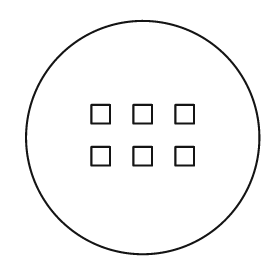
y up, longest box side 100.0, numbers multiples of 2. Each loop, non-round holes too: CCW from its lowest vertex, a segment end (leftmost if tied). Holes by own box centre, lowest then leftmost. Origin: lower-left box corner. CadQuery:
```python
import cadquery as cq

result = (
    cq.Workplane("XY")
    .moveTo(50.0, 50.0)
    .circle(50.0)
    .moveTo(28.0, 38.0)
    .lineTo(36.0, 38.0)
    .lineTo(36.0, 46.0)
    .lineTo(28.0, 46.0)
    .close()
    .moveTo(46.0, 38.0)
    .lineTo(54.0, 38.0)
    .lineTo(54.0, 46.0)
    .lineTo(46.0, 46.0)
    .close()
    .moveTo(64.0, 38.0)
    .lineTo(72.0, 38.0)
    .lineTo(72.0, 46.0)
    .lineTo(64.0, 46.0)
    .close()
    .moveTo(28.0, 56.0)
    .lineTo(36.0, 56.0)
    .lineTo(36.0, 64.0)
    .lineTo(28.0, 64.0)
    .close()
    .moveTo(46.0, 56.0)
    .lineTo(54.0, 56.0)
    .lineTo(54.0, 64.0)
    .lineTo(46.0, 64.0)
    .close()
    .moveTo(64.0, 56.0)
    .lineTo(72.0, 56.0)
    .lineTo(72.0, 64.0)
    .lineTo(64.0, 64.0)
    .close()
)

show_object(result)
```